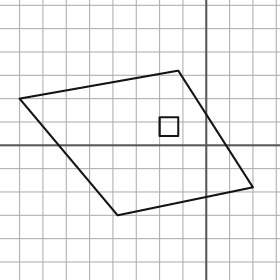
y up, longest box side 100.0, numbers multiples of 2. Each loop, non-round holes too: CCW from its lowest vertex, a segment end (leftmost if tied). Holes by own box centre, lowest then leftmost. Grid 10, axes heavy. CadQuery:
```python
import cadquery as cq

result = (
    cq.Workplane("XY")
    .moveTo(-38.0, -30.0)
    .lineTo(20.0, -18.0)
    .lineTo(-12.0, 32.0)
    .lineTo(-80.0, 20.0)
    .close()
    .moveTo(-20.0, 4.0)
    .lineTo(-12.0, 4.0)
    .lineTo(-12.0, 12.0)
    .lineTo(-20.0, 12.0)
    .close()
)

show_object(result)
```